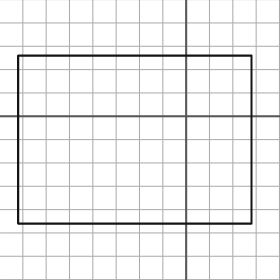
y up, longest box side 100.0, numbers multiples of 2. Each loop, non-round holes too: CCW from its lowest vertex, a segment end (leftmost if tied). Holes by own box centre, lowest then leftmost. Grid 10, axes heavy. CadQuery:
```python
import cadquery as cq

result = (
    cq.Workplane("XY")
    .moveTo(-72.0, -46.0)
    .lineTo(28.0, -46.0)
    .lineTo(28.0, 26.0)
    .lineTo(-72.0, 26.0)
    .close()
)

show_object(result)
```